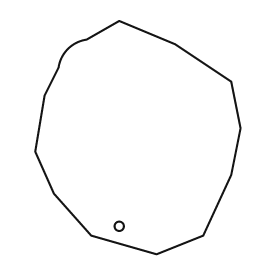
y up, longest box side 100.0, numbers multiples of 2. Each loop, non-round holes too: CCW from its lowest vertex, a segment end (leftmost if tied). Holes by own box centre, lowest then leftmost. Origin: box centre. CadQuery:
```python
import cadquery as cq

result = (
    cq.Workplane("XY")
    .moveTo(8.0, -50.0)
    .lineTo(28.0, -42.0)
    .lineTo(40.0, -16.0)
    .lineTo(44.0, 4.0)
    .lineTo(40.0, 24.0)
    .lineTo(16.0, 40.0)
    .lineTo(-8.0, 50.0)
    .lineTo(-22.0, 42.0)
    .threePointArc((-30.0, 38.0), (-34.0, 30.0))
    .lineTo(-40.0, 18.0)
    .lineTo(-44.0, -6.0)
    .lineTo(-36.0, -24.0)
    .lineTo(-20.0, -42.0)
    .close()
    .moveTo(-8.0, -38.0)
    .circle(2.0)
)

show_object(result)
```